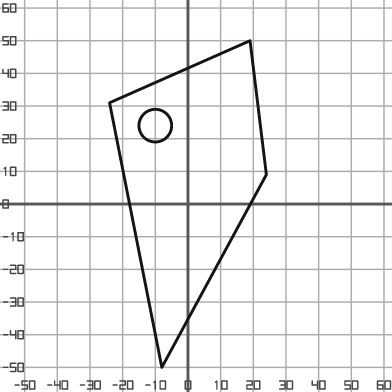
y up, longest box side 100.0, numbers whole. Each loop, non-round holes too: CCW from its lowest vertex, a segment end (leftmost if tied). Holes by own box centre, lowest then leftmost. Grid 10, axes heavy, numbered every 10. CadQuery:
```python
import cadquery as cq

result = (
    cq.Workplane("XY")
    .moveTo(-8.0, -50.0)
    .lineTo(24.0, 9.0)
    .lineTo(19.0, 50.0)
    .lineTo(-24.0, 31.0)
    .close()
    .moveTo(-10.0, 24.0)
    .circle(5.0)
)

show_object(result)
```